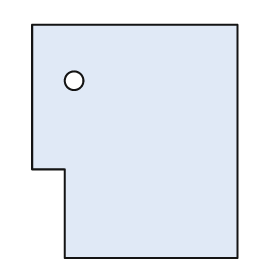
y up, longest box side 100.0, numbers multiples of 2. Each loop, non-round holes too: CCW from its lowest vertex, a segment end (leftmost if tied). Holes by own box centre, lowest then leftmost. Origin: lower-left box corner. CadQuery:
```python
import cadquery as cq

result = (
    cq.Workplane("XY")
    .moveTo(14.0, 0.0)
    .lineTo(88.0, 0.0)
    .lineTo(88.0, 100.0)
    .lineTo(0.0, 100.0)
    .lineTo(0.0, 38.0)
    .lineTo(14.0, 38.0)
    .close()
    .moveTo(18.0, 76.0)
    .circle(4.0)
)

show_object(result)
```